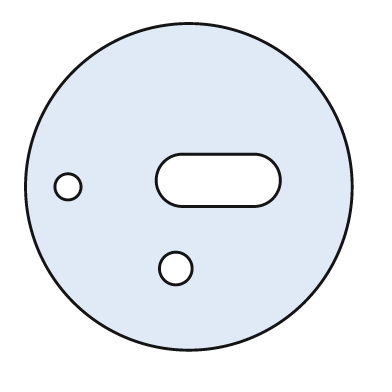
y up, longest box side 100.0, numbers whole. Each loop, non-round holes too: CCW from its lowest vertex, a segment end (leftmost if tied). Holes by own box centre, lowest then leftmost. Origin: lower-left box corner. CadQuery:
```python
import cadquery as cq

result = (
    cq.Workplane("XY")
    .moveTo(50.0, 50.0)
    .circle(50.0)
    .moveTo(46.0, 25.0)
    .circle(5.0)
    .moveTo(13.0, 50.0)
    .circle(4.0)
    .moveTo(48.0, 44.0)
    .lineTo(70.0, 44.0)
    .threePointArc((78.0, 52.0), (70.0, 60.0))
    .lineTo(48.0, 60.0)
    .threePointArc((40.0, 52.0), (48.0, 44.0))
    .close()
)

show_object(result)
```